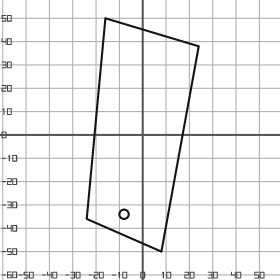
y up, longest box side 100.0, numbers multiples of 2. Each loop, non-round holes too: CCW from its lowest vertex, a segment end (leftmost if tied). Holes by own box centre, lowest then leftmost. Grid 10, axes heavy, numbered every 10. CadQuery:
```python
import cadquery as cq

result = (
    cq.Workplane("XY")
    .moveTo(8.0, -50.0)
    .lineTo(24.0, 38.0)
    .lineTo(-16.0, 50.0)
    .lineTo(-24.0, -36.0)
    .close()
    .moveTo(-8.0, -34.0)
    .circle(2.0)
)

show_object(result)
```